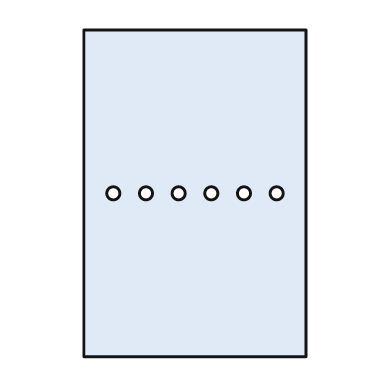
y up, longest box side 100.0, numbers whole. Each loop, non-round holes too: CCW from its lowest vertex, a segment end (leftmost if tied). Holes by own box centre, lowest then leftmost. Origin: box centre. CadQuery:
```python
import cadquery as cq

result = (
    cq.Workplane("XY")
    .moveTo(-34.0, -50.0)
    .lineTo(34.0, -50.0)
    .lineTo(34.0, 50.0)
    .lineTo(-34.0, 50.0)
    .close()
    .moveTo(-25.0, 0.0)
    .circle(2.0)
    .moveTo(-15.0, 0.0)
    .circle(2.0)
    .moveTo(-5.0, 0.0)
    .circle(2.0)
    .moveTo(5.0, 0.0)
    .circle(2.0)
    .moveTo(15.0, 0.0)
    .circle(2.0)
    .moveTo(25.0, 0.0)
    .circle(2.0)
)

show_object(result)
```